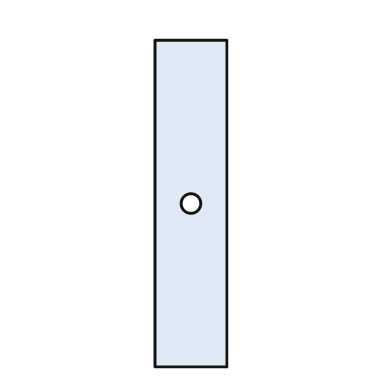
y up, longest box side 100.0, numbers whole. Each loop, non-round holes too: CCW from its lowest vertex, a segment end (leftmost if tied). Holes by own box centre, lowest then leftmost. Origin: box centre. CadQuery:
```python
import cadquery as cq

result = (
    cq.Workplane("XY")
    .moveTo(-11.0, -50.0)
    .lineTo(11.0, -50.0)
    .lineTo(11.0, 50.0)
    .lineTo(-11.0, 50.0)
    .close()
    .moveTo(0.0, 0.0)
    .circle(3.0)
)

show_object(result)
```